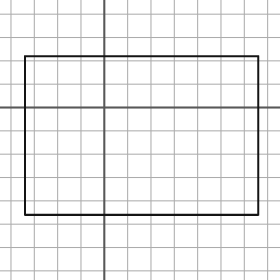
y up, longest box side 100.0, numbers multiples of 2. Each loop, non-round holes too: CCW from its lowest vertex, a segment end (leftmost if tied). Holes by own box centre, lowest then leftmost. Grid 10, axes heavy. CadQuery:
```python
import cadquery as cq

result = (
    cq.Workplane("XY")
    .moveTo(-34.0, -46.0)
    .lineTo(66.0, -46.0)
    .lineTo(66.0, 22.0)
    .lineTo(-34.0, 22.0)
    .close()
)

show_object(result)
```